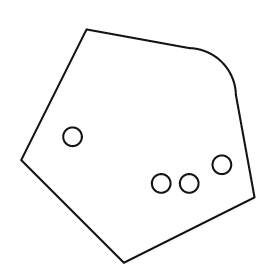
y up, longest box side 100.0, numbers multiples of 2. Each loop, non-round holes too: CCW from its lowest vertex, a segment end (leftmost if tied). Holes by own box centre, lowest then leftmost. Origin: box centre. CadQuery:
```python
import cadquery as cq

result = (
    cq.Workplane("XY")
    .moveTo(-6.0, -50.0)
    .lineTo(50.0, -22.0)
    .lineTo(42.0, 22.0)
    .threePointArc((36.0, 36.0), (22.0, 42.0))
    .lineTo(-22.0, 50.0)
    .lineTo(-50.0, -6.0)
    .close()
    .moveTo(10.0, -16.0)
    .circle(4.0)
    .moveTo(22.0, -16.0)
    .circle(4.0)
    .moveTo(36.0, -8.0)
    .circle(4.0)
    .moveTo(-28.0, 4.0)
    .circle(4.0)
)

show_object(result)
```